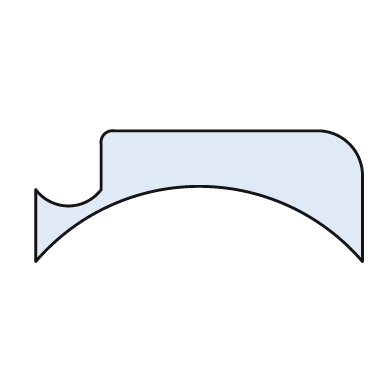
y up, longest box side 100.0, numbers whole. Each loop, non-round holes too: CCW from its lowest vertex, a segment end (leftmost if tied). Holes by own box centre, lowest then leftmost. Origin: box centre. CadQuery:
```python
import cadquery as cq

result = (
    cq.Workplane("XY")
    .moveTo(-50.0, -20.0)
    .threePointArc((0.0, 3.0), (50.0, -20.0))
    .lineTo(50.0, 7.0)
    .threePointArc((46.0, 16.0), (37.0, 20.0))
    .lineTo(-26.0, 20.0)
    .threePointArc((-29.0, 19.0), (-30.0, 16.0))
    .lineTo(-30.0, 2.0)
    .threePointArc((-40.0, -3.0), (-50.0, 2.0))
    .close()
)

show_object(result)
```